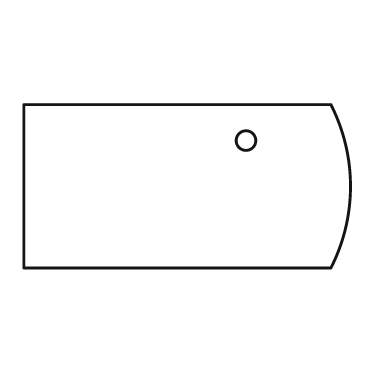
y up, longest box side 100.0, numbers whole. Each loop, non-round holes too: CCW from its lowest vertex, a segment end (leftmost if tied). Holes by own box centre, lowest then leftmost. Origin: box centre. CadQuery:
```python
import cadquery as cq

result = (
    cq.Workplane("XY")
    .moveTo(-50.0, -25.0)
    .lineTo(44.0, -25.0)
    .threePointArc((50.0, 0.0), (44.0, 25.0))
    .lineTo(-50.0, 25.0)
    .close()
    .moveTo(18.0, 14.0)
    .circle(3.0)
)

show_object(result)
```